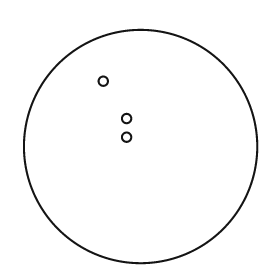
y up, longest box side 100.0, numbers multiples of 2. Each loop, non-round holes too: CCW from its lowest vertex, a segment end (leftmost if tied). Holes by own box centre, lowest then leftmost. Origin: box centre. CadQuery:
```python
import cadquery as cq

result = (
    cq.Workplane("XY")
    .moveTo(0.0, 0.0)
    .circle(50.0)
    .moveTo(-6.0, 4.0)
    .circle(2.0)
    .moveTo(-6.0, 12.0)
    .circle(2.0)
    .moveTo(-16.0, 28.0)
    .circle(2.0)
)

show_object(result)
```